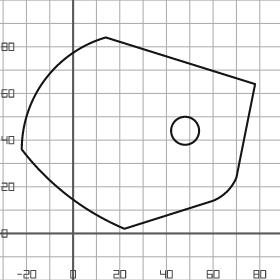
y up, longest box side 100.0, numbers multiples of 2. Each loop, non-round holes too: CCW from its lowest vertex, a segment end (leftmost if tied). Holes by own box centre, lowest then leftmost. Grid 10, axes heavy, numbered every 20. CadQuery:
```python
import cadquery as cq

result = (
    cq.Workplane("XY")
    .moveTo(22.0, 2.0)
    .lineTo(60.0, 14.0)
    .threePointArc((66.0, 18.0), (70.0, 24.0))
    .lineTo(78.0, 64.0)
    .lineTo(14.0, 84.0)
    .threePointArc((-12.0, 66.0), (-22.0, 36.0))
    .threePointArc((-2.0, 16.0), (22.0, 2.0))
    .close()
    .moveTo(48.0, 44.0)
    .circle(6.0)
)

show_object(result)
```